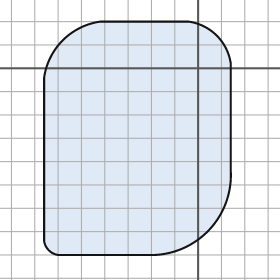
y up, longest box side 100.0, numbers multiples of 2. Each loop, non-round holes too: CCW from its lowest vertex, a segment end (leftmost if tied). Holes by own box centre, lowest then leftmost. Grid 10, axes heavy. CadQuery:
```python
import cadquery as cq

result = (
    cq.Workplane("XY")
    .moveTo(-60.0, -80.0)
    .lineTo(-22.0, -80.0)
    .threePointArc((4.0, -70.0), (14.0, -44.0))
    .lineTo(14.0, 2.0)
    .threePointArc((8.0, 14.0), (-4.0, 20.0))
    .lineTo(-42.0, 20.0)
    .threePointArc((-58.0, 12.0), (-66.0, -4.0))
    .lineTo(-66.0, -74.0)
    .threePointArc((-64.0, -78.0), (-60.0, -80.0))
    .close()
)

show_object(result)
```